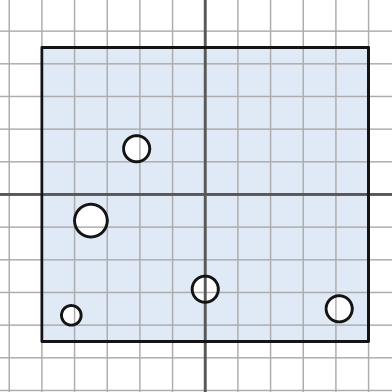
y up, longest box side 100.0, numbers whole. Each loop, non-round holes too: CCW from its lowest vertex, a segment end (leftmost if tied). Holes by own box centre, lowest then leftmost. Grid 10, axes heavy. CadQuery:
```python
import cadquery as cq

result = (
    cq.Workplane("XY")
    .moveTo(-50.0, -45.0)
    .lineTo(50.0, -45.0)
    .lineTo(50.0, 45.0)
    .lineTo(-50.0, 45.0)
    .close()
    .moveTo(-41.0, -37.0)
    .circle(3.0)
    .moveTo(41.0, -35.0)
    .circle(4.0)
    .moveTo(0.0, -29.0)
    .circle(4.0)
    .moveTo(-35.0, -8.0)
    .circle(5.0)
    .moveTo(-21.0, 14.0)
    .circle(4.0)
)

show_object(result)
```